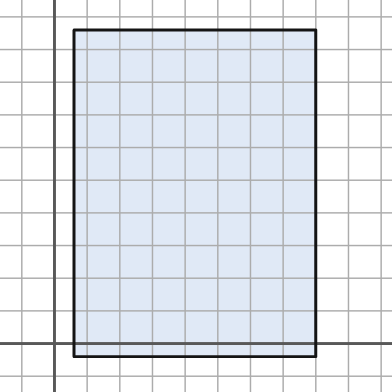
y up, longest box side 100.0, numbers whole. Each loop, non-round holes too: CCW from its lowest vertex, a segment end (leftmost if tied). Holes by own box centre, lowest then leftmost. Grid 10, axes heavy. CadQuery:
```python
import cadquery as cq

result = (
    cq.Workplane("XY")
    .moveTo(6.0, -4.0)
    .lineTo(80.0, -4.0)
    .lineTo(80.0, 96.0)
    .lineTo(6.0, 96.0)
    .close()
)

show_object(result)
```